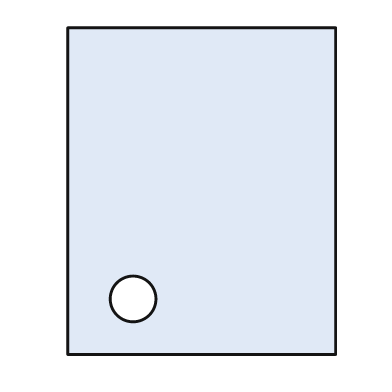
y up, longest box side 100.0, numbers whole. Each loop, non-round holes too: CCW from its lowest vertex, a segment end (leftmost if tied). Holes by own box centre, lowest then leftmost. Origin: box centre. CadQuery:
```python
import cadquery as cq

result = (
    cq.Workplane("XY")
    .moveTo(-41.0, -50.0)
    .lineTo(41.0, -50.0)
    .lineTo(41.0, 50.0)
    .lineTo(-41.0, 50.0)
    .close()
    .moveTo(-21.0, -33.0)
    .circle(7.0)
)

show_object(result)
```